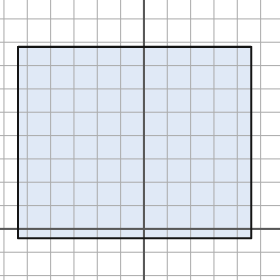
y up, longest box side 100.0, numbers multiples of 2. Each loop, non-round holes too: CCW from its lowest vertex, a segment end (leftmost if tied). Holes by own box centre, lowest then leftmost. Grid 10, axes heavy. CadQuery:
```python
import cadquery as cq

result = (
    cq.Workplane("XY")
    .moveTo(-54.0, -4.0)
    .lineTo(46.0, -4.0)
    .lineTo(46.0, 78.0)
    .lineTo(-54.0, 78.0)
    .close()
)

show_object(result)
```